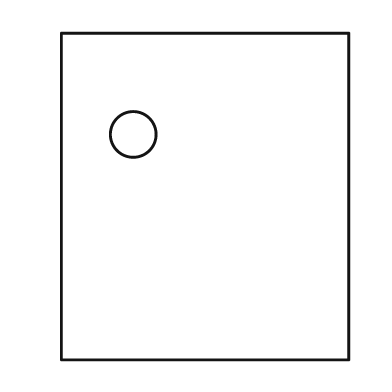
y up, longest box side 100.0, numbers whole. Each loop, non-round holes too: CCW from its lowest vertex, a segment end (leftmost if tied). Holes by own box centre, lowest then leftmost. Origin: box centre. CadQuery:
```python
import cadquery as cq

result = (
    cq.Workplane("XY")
    .moveTo(-44.0, -50.0)
    .lineTo(44.0, -50.0)
    .lineTo(44.0, 50.0)
    .lineTo(-44.0, 50.0)
    .close()
    .moveTo(-22.0, 19.0)
    .circle(7.0)
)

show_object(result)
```